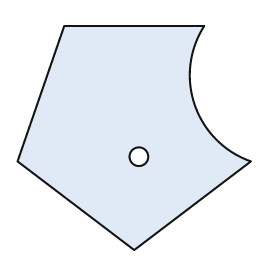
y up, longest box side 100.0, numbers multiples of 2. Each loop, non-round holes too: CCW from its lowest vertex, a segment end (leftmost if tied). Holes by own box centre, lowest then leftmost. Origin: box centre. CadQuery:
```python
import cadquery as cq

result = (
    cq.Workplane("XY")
    .moveTo(0.0, -48.0)
    .lineTo(50.0, -10.0)
    .threePointArc((26.0, 14.0), (30.0, 48.0))
    .lineTo(-30.0, 48.0)
    .lineTo(-50.0, -10.0)
    .close()
    .moveTo(2.0, -8.0)
    .circle(4.0)
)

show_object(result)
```